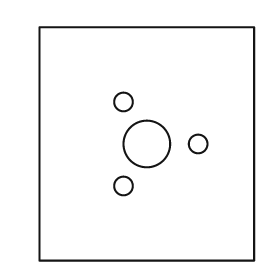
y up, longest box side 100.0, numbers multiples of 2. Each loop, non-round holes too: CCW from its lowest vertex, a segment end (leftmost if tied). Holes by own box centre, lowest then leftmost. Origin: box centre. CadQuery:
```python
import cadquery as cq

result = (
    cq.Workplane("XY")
    .moveTo(-46.0, -50.0)
    .lineTo(46.0, -50.0)
    .lineTo(46.0, 50.0)
    .lineTo(-46.0, 50.0)
    .close()
    .moveTo(-10.0, -18.0)
    .circle(4.0)
    .moveTo(0.0, 0.0)
    .circle(10.0)
    .moveTo(22.0, 0.0)
    .circle(4.0)
    .moveTo(-10.0, 18.0)
    .circle(4.0)
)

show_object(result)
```